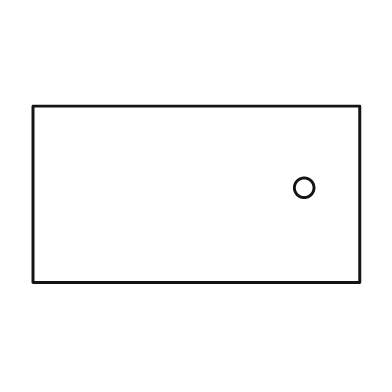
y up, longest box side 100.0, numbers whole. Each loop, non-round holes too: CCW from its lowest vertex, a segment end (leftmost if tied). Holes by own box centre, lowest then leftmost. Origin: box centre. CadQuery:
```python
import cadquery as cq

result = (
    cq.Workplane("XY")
    .moveTo(-50.0, -27.0)
    .lineTo(50.0, -27.0)
    .lineTo(50.0, 27.0)
    .lineTo(-50.0, 27.0)
    .close()
    .moveTo(33.0, 2.0)
    .circle(3.0)
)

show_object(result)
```